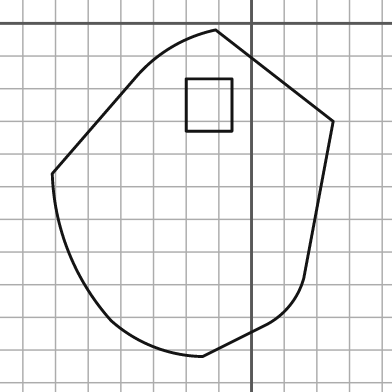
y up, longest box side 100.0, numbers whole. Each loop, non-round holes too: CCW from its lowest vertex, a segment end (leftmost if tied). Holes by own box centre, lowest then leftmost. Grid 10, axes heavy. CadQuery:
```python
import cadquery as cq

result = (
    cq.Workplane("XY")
    .moveTo(-15.0, -102.0)
    .lineTo(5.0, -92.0)
    .threePointArc((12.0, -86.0), (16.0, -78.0))
    .lineTo(25.0, -30.0)
    .lineTo(-11.0, -2.0)
    .threePointArc((-24.0, -7.0), (-35.0, -16.0))
    .lineTo(-61.0, -46.0)
    .threePointArc((-56.0, -70.0), (-43.0, -91.0))
    .threePointArc((-30.0, -99.0), (-15.0, -102.0))
    .close()
    .moveTo(-20.0, -33.0)
    .lineTo(-6.0, -33.0)
    .lineTo(-6.0, -17.0)
    .lineTo(-20.0, -17.0)
    .close()
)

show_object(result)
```